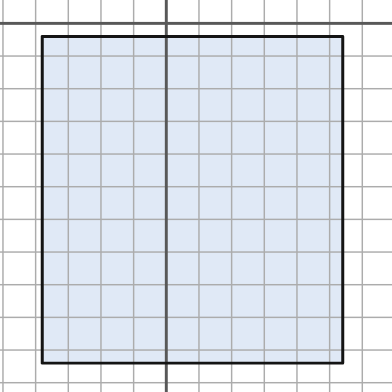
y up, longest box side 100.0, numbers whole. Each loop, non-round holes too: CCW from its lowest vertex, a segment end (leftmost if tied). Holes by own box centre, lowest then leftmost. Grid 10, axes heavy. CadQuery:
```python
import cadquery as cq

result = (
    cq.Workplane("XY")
    .moveTo(-38.0, -104.0)
    .lineTo(54.0, -104.0)
    .lineTo(54.0, -4.0)
    .lineTo(-38.0, -4.0)
    .close()
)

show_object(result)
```